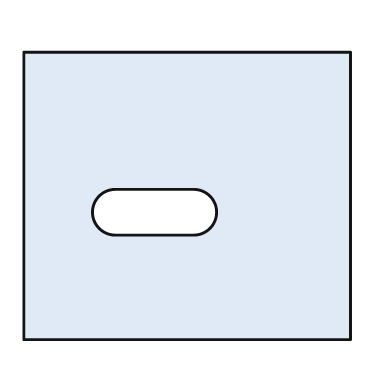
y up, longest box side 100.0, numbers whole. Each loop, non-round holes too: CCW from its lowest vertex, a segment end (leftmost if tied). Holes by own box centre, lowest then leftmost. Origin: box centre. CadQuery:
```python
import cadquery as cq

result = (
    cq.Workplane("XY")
    .moveTo(-50.0, -44.0)
    .lineTo(50.0, -44.0)
    .lineTo(50.0, 44.0)
    .lineTo(-50.0, 44.0)
    .close()
    .moveTo(-22.0, -12.0)
    .lineTo(2.0, -12.0)
    .threePointArc((9.0, -5.0), (2.0, 2.0))
    .lineTo(-22.0, 2.0)
    .threePointArc((-29.0, -5.0), (-22.0, -12.0))
    .close()
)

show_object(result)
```